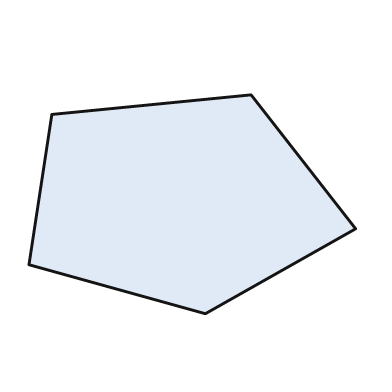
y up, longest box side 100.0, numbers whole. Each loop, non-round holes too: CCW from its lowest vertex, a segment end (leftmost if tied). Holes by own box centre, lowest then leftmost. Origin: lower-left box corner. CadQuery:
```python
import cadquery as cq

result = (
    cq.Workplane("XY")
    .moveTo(54.0, 0.0)
    .lineTo(100.0, 26.0)
    .lineTo(68.0, 67.0)
    .lineTo(7.0, 61.0)
    .lineTo(0.0, 15.0)
    .close()
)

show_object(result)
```